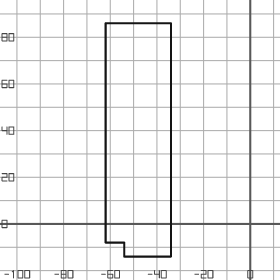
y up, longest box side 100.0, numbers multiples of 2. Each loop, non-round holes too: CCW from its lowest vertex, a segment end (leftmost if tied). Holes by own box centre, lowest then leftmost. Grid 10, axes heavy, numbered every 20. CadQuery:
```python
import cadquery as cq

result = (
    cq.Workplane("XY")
    .moveTo(-54.0, -14.0)
    .lineTo(-34.0, -14.0)
    .lineTo(-34.0, 86.0)
    .lineTo(-62.0, 86.0)
    .lineTo(-62.0, -8.0)
    .lineTo(-54.0, -8.0)
    .close()
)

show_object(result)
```